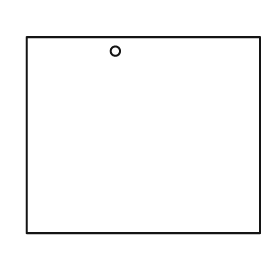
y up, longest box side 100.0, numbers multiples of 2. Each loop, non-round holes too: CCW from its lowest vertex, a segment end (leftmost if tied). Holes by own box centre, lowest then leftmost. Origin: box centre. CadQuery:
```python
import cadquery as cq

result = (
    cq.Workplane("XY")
    .moveTo(-50.0, -42.0)
    .lineTo(50.0, -42.0)
    .lineTo(50.0, 42.0)
    .lineTo(-50.0, 42.0)
    .close()
    .moveTo(-12.0, 36.0)
    .circle(2.0)
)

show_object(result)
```